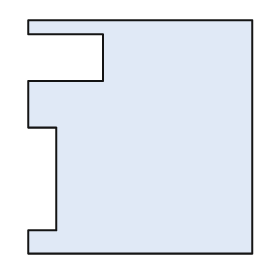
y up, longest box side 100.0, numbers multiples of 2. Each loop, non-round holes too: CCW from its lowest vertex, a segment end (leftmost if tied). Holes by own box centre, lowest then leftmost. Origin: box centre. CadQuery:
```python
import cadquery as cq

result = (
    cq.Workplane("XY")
    .moveTo(-48.0, -50.0)
    .lineTo(48.0, -50.0)
    .lineTo(48.0, 50.0)
    .lineTo(-48.0, 50.0)
    .lineTo(-48.0, 44.0)
    .lineTo(-16.0, 44.0)
    .lineTo(-16.0, 24.0)
    .lineTo(-48.0, 24.0)
    .lineTo(-48.0, 4.0)
    .lineTo(-36.0, 4.0)
    .lineTo(-36.0, -40.0)
    .lineTo(-48.0, -40.0)
    .close()
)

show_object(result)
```